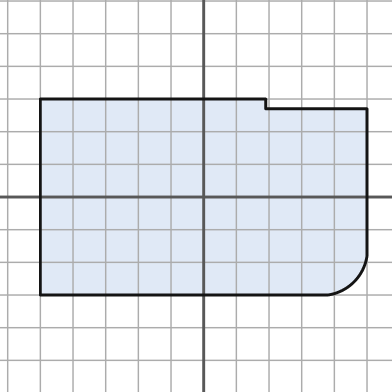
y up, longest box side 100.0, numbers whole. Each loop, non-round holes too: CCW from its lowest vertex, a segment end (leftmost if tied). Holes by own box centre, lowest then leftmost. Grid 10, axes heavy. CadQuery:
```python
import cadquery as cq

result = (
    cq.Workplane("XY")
    .moveTo(-50.0, -30.0)
    .lineTo(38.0, -30.0)
    .threePointArc((46.0, -26.0), (50.0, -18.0))
    .lineTo(50.0, 27.0)
    .lineTo(19.0, 27.0)
    .lineTo(19.0, 30.0)
    .lineTo(-50.0, 30.0)
    .close()
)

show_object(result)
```